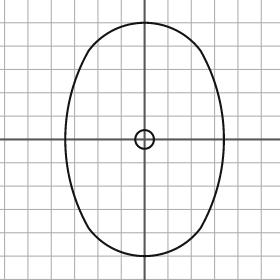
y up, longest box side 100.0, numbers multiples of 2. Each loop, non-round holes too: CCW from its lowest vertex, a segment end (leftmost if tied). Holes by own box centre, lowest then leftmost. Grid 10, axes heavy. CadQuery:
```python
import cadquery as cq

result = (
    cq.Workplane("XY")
    .moveTo(-24.0, -38.0)
    .threePointArc((0.0, -50.0), (24.0, -38.0))
    .threePointArc((34.0, 0.0), (24.0, 38.0))
    .threePointArc((0.0, 50.0), (-24.0, 38.0))
    .threePointArc((-34.0, 0.0), (-24.0, -38.0))
    .close()
    .moveTo(0.0, 0.0)
    .circle(4.0)
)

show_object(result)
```